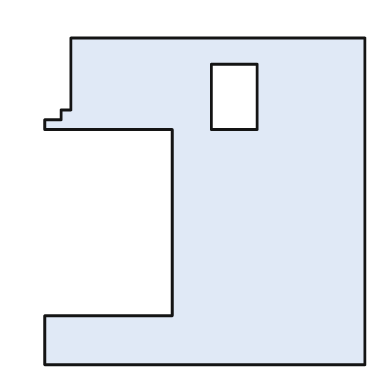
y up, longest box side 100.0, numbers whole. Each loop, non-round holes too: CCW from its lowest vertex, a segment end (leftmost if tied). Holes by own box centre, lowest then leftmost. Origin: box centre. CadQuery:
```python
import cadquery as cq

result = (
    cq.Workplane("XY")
    .moveTo(-49.0, -50.0)
    .lineTo(49.0, -50.0)
    .lineTo(49.0, 50.0)
    .lineTo(-41.0, 50.0)
    .lineTo(-41.0, 28.0)
    .lineTo(-44.0, 28.0)
    .lineTo(-44.0, 25.0)
    .lineTo(-49.0, 25.0)
    .lineTo(-49.0, 22.0)
    .lineTo(-10.0, 22.0)
    .lineTo(-10.0, -35.0)
    .lineTo(-49.0, -35.0)
    .close()
    .moveTo(2.0, 22.0)
    .lineTo(16.0, 22.0)
    .lineTo(16.0, 42.0)
    .lineTo(2.0, 42.0)
    .close()
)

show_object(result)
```